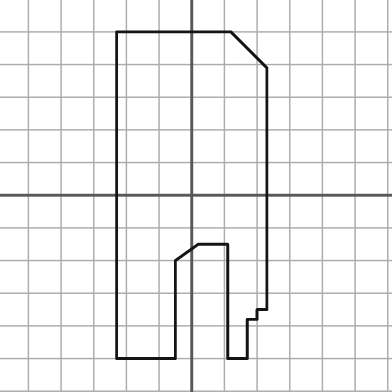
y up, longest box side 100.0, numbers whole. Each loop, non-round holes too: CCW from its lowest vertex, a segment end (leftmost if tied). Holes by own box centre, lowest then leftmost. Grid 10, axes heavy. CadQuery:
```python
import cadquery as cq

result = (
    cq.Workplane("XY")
    .moveTo(-23.0, -50.0)
    .lineTo(-5.0, -50.0)
    .lineTo(-5.0, -20.0)
    .lineTo(2.0, -15.0)
    .lineTo(11.0, -15.0)
    .lineTo(11.0, -50.0)
    .lineTo(17.0, -50.0)
    .lineTo(17.0, -38.0)
    .lineTo(20.0, -38.0)
    .lineTo(20.0, -35.0)
    .lineTo(23.0, -35.0)
    .lineTo(23.0, 39.0)
    .lineTo(12.0, 50.0)
    .lineTo(-23.0, 50.0)
    .close()
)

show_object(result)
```